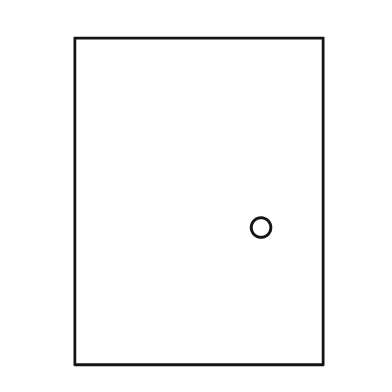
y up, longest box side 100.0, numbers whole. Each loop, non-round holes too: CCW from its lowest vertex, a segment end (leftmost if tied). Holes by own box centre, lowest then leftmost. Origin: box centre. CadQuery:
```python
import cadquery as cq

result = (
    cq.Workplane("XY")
    .moveTo(-38.0, -50.0)
    .lineTo(38.0, -50.0)
    .lineTo(38.0, 50.0)
    .lineTo(-38.0, 50.0)
    .close()
    .moveTo(19.0, -8.0)
    .circle(3.0)
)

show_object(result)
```